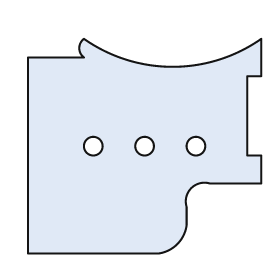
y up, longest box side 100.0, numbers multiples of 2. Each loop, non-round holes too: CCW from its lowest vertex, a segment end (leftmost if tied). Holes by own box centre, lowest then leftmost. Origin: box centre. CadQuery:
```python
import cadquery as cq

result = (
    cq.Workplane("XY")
    .moveTo(-50.0, -46.0)
    .lineTo(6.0, -46.0)
    .threePointArc((14.0, -42.0), (18.0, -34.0))
    .lineTo(18.0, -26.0)
    .threePointArc((20.0, -18.0), (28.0, -16.0))
    .lineTo(50.0, -16.0)
    .lineTo(50.0, -4.0)
    .lineTo(44.0, -4.0)
    .lineTo(44.0, 30.0)
    .lineTo(50.0, 30.0)
    .lineTo(50.0, 46.0)
    .threePointArc((12.0, 34.0), (-26.0, 46.0))
    .threePointArc((-28.0, 42.0), (-26.0, 38.0))
    .lineTo(-50.0, 38.0)
    .close()
    .moveTo(-22.0, 0.0)
    .circle(4.0)
    .moveTo(0.0, 0.0)
    .circle(4.0)
    .moveTo(22.0, 0.0)
    .circle(4.0)
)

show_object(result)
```